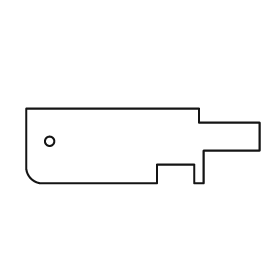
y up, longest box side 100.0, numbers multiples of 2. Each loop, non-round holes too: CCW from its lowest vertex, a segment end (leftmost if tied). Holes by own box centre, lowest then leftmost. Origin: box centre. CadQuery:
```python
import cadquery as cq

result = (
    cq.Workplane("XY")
    .moveTo(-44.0, -16.0)
    .lineTo(6.0, -16.0)
    .lineTo(6.0, -8.0)
    .lineTo(22.0, -8.0)
    .lineTo(22.0, -16.0)
    .lineTo(26.0, -16.0)
    .lineTo(26.0, -2.0)
    .lineTo(50.0, -2.0)
    .lineTo(50.0, 10.0)
    .lineTo(24.0, 10.0)
    .lineTo(24.0, 16.0)
    .lineTo(-50.0, 16.0)
    .lineTo(-50.0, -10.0)
    .threePointArc((-48.0, -14.0), (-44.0, -16.0))
    .close()
    .moveTo(-40.0, 2.0)
    .circle(2.0)
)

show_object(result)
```